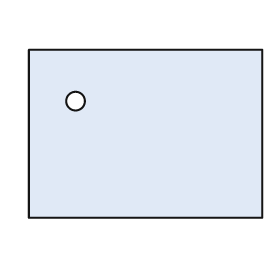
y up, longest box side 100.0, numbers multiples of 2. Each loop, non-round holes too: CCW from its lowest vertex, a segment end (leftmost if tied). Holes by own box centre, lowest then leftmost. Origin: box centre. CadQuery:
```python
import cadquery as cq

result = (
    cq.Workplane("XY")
    .moveTo(-50.0, -36.0)
    .lineTo(50.0, -36.0)
    .lineTo(50.0, 36.0)
    .lineTo(-50.0, 36.0)
    .close()
    .moveTo(-30.0, 14.0)
    .circle(4.0)
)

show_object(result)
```